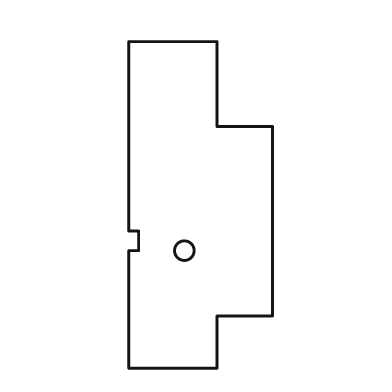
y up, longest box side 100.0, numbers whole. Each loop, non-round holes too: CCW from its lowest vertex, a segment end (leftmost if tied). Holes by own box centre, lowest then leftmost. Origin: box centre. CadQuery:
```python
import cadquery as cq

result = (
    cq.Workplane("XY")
    .moveTo(-22.0, -50.0)
    .lineTo(5.0, -50.0)
    .lineTo(5.0, -34.0)
    .lineTo(22.0, -34.0)
    .lineTo(22.0, 24.0)
    .lineTo(5.0, 24.0)
    .lineTo(5.0, 50.0)
    .lineTo(-22.0, 50.0)
    .lineTo(-22.0, -8.0)
    .lineTo(-19.0, -8.0)
    .lineTo(-19.0, -14.0)
    .lineTo(-22.0, -14.0)
    .close()
    .moveTo(-5.0, -14.0)
    .circle(3.0)
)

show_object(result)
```